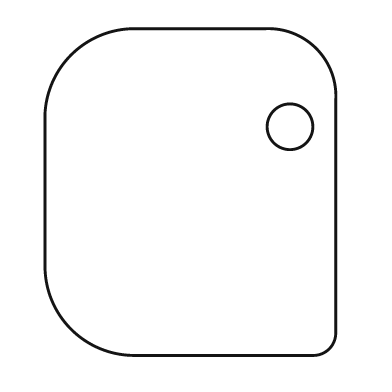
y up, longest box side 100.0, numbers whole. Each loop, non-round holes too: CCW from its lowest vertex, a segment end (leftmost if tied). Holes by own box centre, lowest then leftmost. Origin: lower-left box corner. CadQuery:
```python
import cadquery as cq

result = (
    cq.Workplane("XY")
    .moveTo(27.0, 0.0)
    .lineTo(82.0, 0.0)
    .threePointArc((87.0, 2.0), (89.0, 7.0))
    .lineTo(89.0, 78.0)
    .threePointArc((83.0, 94.0), (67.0, 100.0))
    .lineTo(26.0, 100.0)
    .threePointArc((8.0, 92.0), (0.0, 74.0))
    .lineTo(0.0, 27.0)
    .threePointArc((8.0, 8.0), (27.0, 0.0))
    .close()
    .moveTo(75.0, 70.0)
    .circle(7.0)
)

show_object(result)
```